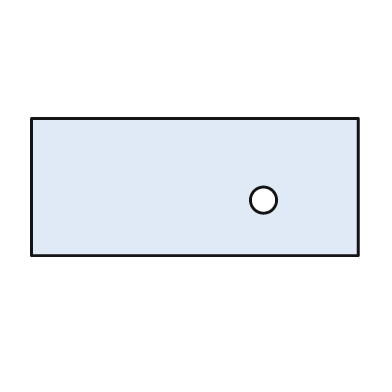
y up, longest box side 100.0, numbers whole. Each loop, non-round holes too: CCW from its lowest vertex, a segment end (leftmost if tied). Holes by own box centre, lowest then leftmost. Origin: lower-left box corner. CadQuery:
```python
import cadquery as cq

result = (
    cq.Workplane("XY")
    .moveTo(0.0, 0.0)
    .lineTo(100.0, 0.0)
    .lineTo(100.0, 42.0)
    .lineTo(0.0, 42.0)
    .close()
    .moveTo(71.0, 17.0)
    .circle(4.0)
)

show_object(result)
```